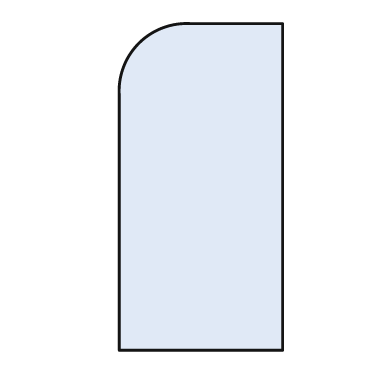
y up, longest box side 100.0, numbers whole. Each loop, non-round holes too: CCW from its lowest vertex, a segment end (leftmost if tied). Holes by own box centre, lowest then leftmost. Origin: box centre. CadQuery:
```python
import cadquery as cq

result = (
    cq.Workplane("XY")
    .moveTo(-25.0, -50.0)
    .lineTo(25.0, -50.0)
    .lineTo(25.0, 50.0)
    .lineTo(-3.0, 50.0)
    .threePointArc((-19.0, 44.0), (-25.0, 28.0))
    .close()
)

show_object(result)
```